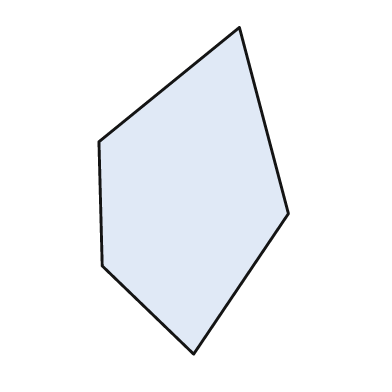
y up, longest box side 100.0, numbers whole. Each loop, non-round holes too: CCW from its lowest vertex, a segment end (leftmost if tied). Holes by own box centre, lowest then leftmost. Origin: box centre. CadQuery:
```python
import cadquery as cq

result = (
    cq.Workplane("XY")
    .moveTo(0.0, -50.0)
    .lineTo(29.0, -7.0)
    .lineTo(14.0, 50.0)
    .lineTo(-29.0, 15.0)
    .lineTo(-28.0, -23.0)
    .close()
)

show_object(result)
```